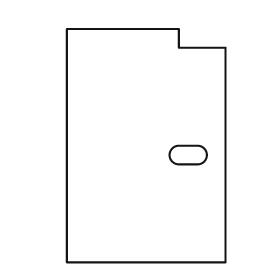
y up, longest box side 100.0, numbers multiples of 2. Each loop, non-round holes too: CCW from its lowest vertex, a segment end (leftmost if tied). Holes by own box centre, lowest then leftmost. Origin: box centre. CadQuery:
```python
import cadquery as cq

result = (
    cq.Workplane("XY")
    .moveTo(-34.0, -50.0)
    .lineTo(34.0, -50.0)
    .lineTo(34.0, 42.0)
    .lineTo(14.0, 42.0)
    .lineTo(14.0, 50.0)
    .lineTo(-34.0, 50.0)
    .close()
    .moveTo(14.0, -8.0)
    .lineTo(22.0, -8.0)
    .threePointArc((26.0, -4.0), (22.0, 0.0))
    .lineTo(14.0, 0.0)
    .threePointArc((10.0, -4.0), (14.0, -8.0))
    .close()
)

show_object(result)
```